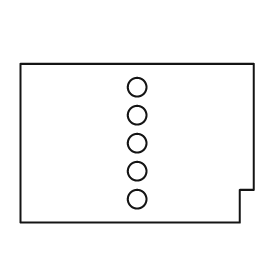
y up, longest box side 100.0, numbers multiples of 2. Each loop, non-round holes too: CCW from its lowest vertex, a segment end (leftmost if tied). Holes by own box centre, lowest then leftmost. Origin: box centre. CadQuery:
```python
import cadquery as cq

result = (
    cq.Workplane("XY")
    .moveTo(-50.0, -34.0)
    .lineTo(44.0, -34.0)
    .lineTo(44.0, -20.0)
    .lineTo(50.0, -20.0)
    .lineTo(50.0, 34.0)
    .lineTo(-50.0, 34.0)
    .close()
    .moveTo(0.0, -24.0)
    .circle(4.0)
    .moveTo(0.0, -12.0)
    .circle(4.0)
    .moveTo(0.0, 0.0)
    .circle(4.0)
    .moveTo(0.0, 12.0)
    .circle(4.0)
    .moveTo(0.0, 24.0)
    .circle(4.0)
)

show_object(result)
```